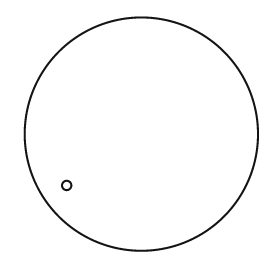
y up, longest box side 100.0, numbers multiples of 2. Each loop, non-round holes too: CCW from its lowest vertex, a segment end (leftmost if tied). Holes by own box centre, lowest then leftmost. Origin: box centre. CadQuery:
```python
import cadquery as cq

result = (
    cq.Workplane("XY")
    .moveTo(0.0, 0.0)
    .circle(50.0)
    .moveTo(-32.0, -22.0)
    .circle(2.0)
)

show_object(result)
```